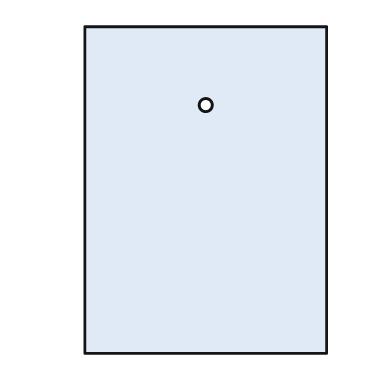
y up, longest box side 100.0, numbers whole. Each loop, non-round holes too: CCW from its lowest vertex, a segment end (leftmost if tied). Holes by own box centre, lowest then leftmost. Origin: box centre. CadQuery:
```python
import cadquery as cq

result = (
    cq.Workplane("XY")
    .moveTo(-37.0, -50.0)
    .lineTo(37.0, -50.0)
    .lineTo(37.0, 50.0)
    .lineTo(-37.0, 50.0)
    .close()
    .moveTo(0.0, 26.0)
    .circle(2.0)
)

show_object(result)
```